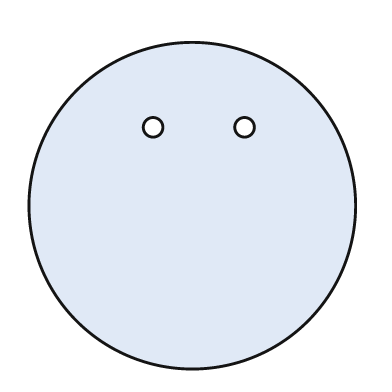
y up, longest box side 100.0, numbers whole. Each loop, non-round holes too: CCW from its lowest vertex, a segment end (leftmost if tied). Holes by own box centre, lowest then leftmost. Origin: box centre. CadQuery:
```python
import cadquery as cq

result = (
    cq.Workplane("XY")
    .moveTo(0.0, 0.0)
    .circle(50.0)
    .moveTo(-12.0, 24.0)
    .circle(3.0)
    .moveTo(16.0, 24.0)
    .circle(3.0)
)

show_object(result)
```